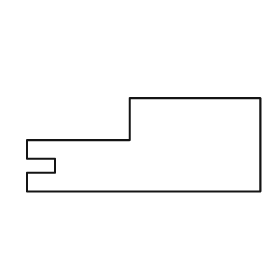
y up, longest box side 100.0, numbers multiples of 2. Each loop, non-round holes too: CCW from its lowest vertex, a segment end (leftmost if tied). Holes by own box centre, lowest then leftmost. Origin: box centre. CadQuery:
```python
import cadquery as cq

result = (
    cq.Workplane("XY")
    .moveTo(-50.0, -20.0)
    .lineTo(50.0, -20.0)
    .lineTo(50.0, 20.0)
    .lineTo(-6.0, 20.0)
    .lineTo(-6.0, 2.0)
    .lineTo(-50.0, 2.0)
    .lineTo(-50.0, -6.0)
    .lineTo(-38.0, -6.0)
    .lineTo(-38.0, -12.0)
    .lineTo(-50.0, -12.0)
    .close()
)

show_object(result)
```